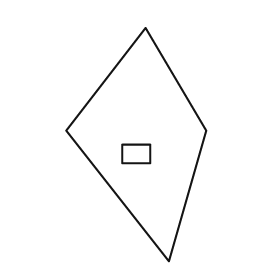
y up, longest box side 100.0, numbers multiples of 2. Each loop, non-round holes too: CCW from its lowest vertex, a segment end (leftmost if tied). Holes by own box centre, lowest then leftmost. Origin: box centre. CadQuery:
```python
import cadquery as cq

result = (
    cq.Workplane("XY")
    .moveTo(14.0, -50.0)
    .lineTo(30.0, 6.0)
    .lineTo(4.0, 50.0)
    .lineTo(-30.0, 6.0)
    .close()
    .moveTo(-6.0, -8.0)
    .lineTo(6.0, -8.0)
    .lineTo(6.0, 0.0)
    .lineTo(-6.0, 0.0)
    .close()
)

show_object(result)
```